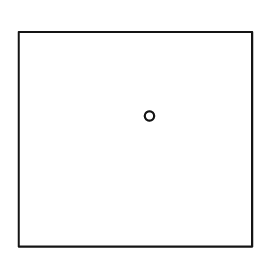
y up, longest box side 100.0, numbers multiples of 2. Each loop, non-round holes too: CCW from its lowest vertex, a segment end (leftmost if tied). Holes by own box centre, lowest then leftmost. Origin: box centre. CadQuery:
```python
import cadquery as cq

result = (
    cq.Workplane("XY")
    .moveTo(-50.0, -46.0)
    .lineTo(50.0, -46.0)
    .lineTo(50.0, 46.0)
    .lineTo(-50.0, 46.0)
    .close()
    .moveTo(6.0, 10.0)
    .circle(2.0)
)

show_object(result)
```